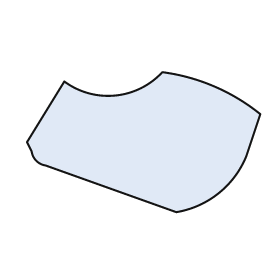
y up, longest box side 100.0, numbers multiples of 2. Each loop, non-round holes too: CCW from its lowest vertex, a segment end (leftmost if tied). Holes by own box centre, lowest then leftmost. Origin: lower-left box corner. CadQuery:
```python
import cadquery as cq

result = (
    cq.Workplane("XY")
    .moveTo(64.0, 0.0)
    .threePointArc((82.0, 8.0), (94.0, 24.0))
    .lineTo(100.0, 42.0)
    .threePointArc((80.0, 54.0), (58.0, 60.0))
    .threePointArc((38.0, 50.0), (16.0, 56.0))
    .lineTo(0.0, 30.0)
    .lineTo(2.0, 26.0)
    .threePointArc((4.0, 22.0), (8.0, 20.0))
    .close()
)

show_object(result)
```